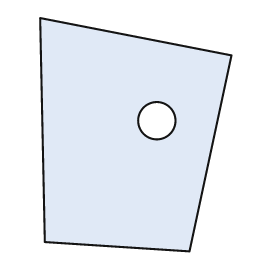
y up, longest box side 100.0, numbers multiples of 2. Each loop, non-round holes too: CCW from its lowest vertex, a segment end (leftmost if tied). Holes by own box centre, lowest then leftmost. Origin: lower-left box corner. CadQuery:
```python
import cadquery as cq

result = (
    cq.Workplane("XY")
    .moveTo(64.0, 0.0)
    .lineTo(82.0, 84.0)
    .lineTo(0.0, 100.0)
    .lineTo(2.0, 4.0)
    .close()
    .moveTo(50.0, 56.0)
    .circle(8.0)
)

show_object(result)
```